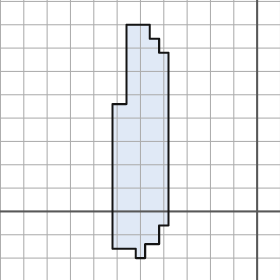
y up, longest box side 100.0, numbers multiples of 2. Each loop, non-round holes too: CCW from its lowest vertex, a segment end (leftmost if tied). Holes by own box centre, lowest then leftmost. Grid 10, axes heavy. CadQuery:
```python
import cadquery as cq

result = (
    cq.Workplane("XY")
    .moveTo(-52.0, -20.0)
    .lineTo(-48.0, -20.0)
    .lineTo(-48.0, -14.0)
    .lineTo(-42.0, -14.0)
    .lineTo(-42.0, -6.0)
    .lineTo(-38.0, -6.0)
    .lineTo(-38.0, 68.0)
    .lineTo(-42.0, 68.0)
    .lineTo(-42.0, 74.0)
    .lineTo(-46.0, 74.0)
    .lineTo(-46.0, 80.0)
    .lineTo(-56.0, 80.0)
    .lineTo(-56.0, 46.0)
    .lineTo(-62.0, 46.0)
    .lineTo(-62.0, -16.0)
    .lineTo(-52.0, -16.0)
    .close()
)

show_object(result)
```